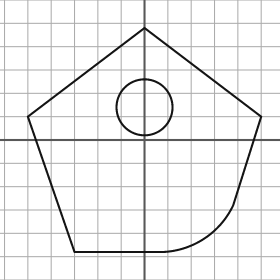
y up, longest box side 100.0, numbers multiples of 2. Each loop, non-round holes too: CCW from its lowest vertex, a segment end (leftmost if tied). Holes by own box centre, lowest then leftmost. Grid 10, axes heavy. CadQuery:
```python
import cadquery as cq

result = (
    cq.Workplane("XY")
    .moveTo(-30.0, -48.0)
    .lineTo(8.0, -48.0)
    .threePointArc((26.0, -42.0), (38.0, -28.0))
    .lineTo(50.0, 10.0)
    .lineTo(0.0, 48.0)
    .lineTo(-50.0, 10.0)
    .close()
    .moveTo(0.0, 14.0)
    .circle(12.0)
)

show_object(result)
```